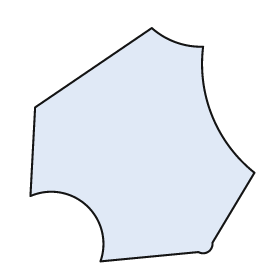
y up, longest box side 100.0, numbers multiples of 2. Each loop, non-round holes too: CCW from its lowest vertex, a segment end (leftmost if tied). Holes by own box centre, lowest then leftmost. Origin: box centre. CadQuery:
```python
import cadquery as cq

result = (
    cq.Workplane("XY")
    .moveTo(-18.0, -50.0)
    .lineTo(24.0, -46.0)
    .threePointArc((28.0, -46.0), (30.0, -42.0))
    .lineTo(48.0, -12.0)
    .threePointArc((30.0, 12.0), (26.0, 42.0))
    .threePointArc((14.0, 44.0), (4.0, 50.0))
    .lineTo(-46.0, 16.0)
    .lineTo(-48.0, -22.0)
    .threePointArc((-24.0, -26.0), (-18.0, -50.0))
    .close()
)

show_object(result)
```